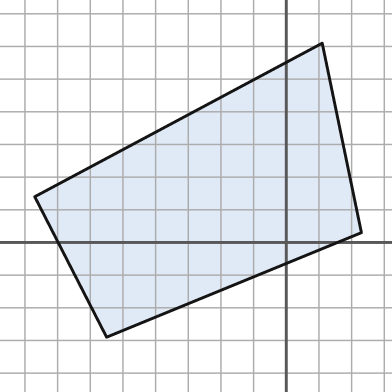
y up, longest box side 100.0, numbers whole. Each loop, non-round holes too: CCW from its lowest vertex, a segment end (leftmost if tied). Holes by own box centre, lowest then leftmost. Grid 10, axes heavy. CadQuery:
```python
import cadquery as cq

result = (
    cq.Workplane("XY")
    .moveTo(-55.0, -29.0)
    .lineTo(23.0, 3.0)
    .lineTo(11.0, 61.0)
    .lineTo(-77.0, 14.0)
    .close()
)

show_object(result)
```